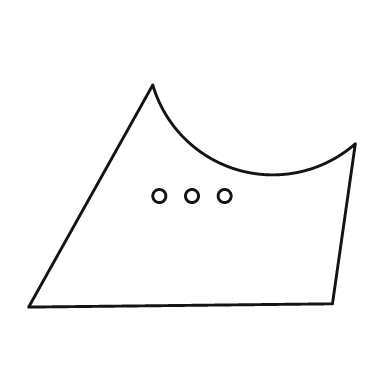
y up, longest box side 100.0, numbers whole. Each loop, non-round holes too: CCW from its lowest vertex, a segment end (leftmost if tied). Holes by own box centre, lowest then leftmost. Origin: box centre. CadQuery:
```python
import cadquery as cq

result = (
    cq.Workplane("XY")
    .moveTo(-50.0, -34.0)
    .lineTo(43.0, -33.0)
    .lineTo(50.0, 16.0)
    .threePointArc((14.0, 8.0), (-12.0, 34.0))
    .close()
    .moveTo(-10.0, 0.0)
    .circle(2.0)
    .moveTo(0.0, 0.0)
    .circle(2.0)
    .moveTo(10.0, 0.0)
    .circle(2.0)
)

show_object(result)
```